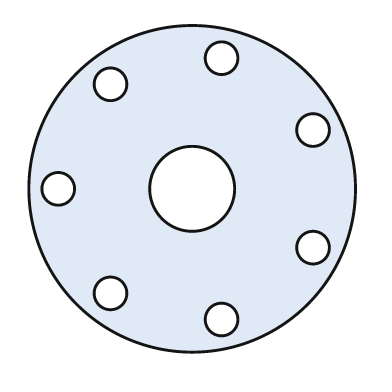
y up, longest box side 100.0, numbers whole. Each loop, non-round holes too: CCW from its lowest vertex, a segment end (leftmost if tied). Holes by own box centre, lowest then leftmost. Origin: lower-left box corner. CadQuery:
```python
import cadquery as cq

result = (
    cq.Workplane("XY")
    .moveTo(50.0, 50.0)
    .circle(50.0)
    .moveTo(59.0, 10.0)
    .circle(5.0)
    .moveTo(25.0, 18.0)
    .circle(5.0)
    .moveTo(87.0, 32.0)
    .circle(5.0)
    .moveTo(9.0, 50.0)
    .circle(5.0)
    .moveTo(50.0, 50.0)
    .circle(13.0)
    .moveTo(87.0, 68.0)
    .circle(5.0)
    .moveTo(25.0, 82.0)
    .circle(5.0)
    .moveTo(59.0, 90.0)
    .circle(5.0)
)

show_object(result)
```